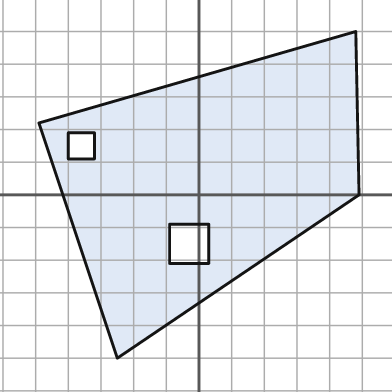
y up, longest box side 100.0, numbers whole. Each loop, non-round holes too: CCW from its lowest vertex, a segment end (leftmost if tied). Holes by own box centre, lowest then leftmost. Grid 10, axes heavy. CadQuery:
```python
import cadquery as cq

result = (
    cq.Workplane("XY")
    .moveTo(-25.0, -50.0)
    .lineTo(49.0, 0.0)
    .lineTo(48.0, 50.0)
    .lineTo(-49.0, 22.0)
    .close()
    .moveTo(-9.0, -21.0)
    .lineTo(3.0, -21.0)
    .lineTo(3.0, -9.0)
    .lineTo(-9.0, -9.0)
    .close()
    .moveTo(-40.0, 11.0)
    .lineTo(-32.0, 11.0)
    .lineTo(-32.0, 19.0)
    .lineTo(-40.0, 19.0)
    .close()
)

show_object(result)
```